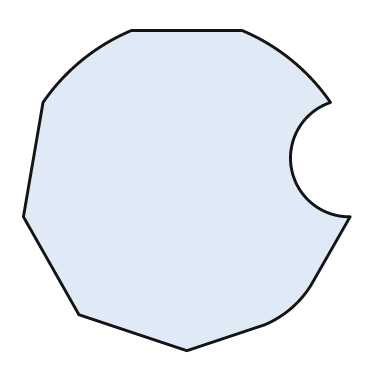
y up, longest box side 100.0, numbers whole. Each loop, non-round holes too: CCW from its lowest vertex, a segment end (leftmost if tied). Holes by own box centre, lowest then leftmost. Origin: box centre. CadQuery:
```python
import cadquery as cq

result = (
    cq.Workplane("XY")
    .moveTo(0.0, -49.0)
    .lineTo(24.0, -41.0)
    .threePointArc((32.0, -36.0), (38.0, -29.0))
    .lineTo(50.0, -8.0)
    .threePointArc((32.0, 7.0), (44.0, 27.0))
    .threePointArc((32.0, 40.0), (17.0, 49.0))
    .lineTo(-17.0, 49.0)
    .threePointArc((-32.0, 40.0), (-44.0, 27.0))
    .lineTo(-50.0, -8.0)
    .lineTo(-33.0, -38.0)
    .close()
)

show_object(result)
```